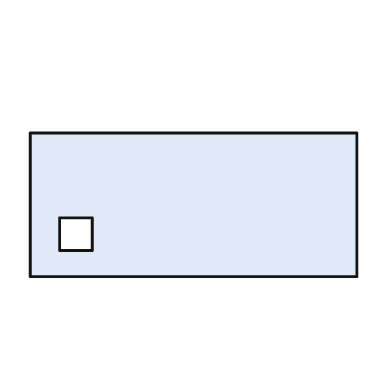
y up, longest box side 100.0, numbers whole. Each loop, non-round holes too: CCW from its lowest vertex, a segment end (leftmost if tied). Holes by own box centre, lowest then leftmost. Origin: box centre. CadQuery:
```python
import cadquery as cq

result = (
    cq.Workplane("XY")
    .moveTo(-50.0, -22.0)
    .lineTo(50.0, -22.0)
    .lineTo(50.0, 22.0)
    .lineTo(-50.0, 22.0)
    .close()
    .moveTo(-41.0, -14.0)
    .lineTo(-31.0, -14.0)
    .lineTo(-31.0, -4.0)
    .lineTo(-41.0, -4.0)
    .close()
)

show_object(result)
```